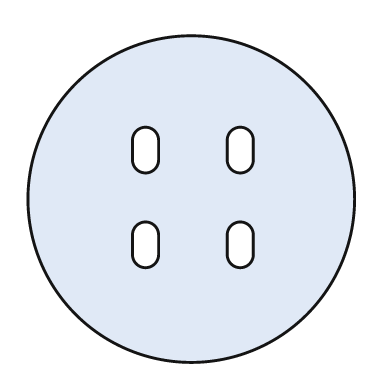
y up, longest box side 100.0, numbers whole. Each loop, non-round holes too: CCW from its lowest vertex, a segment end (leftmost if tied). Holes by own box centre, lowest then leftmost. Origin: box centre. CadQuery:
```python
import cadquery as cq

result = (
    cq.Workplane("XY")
    .moveTo(0.0, 0.0)
    .circle(50.0)
    .moveTo(-18.0, -17.0)
    .threePointArc((-14.0, -21.0), (-10.0, -17.0))
    .lineTo(-10.0, -11.0)
    .threePointArc((-14.0, -7.0), (-18.0, -11.0))
    .close()
    .moveTo(11.0, -17.0)
    .threePointArc((15.0, -21.0), (19.0, -17.0))
    .lineTo(19.0, -11.0)
    .threePointArc((15.0, -7.0), (11.0, -11.0))
    .close()
    .moveTo(-18.0, 12.0)
    .threePointArc((-14.0, 8.0), (-10.0, 12.0))
    .lineTo(-10.0, 18.0)
    .threePointArc((-14.0, 22.0), (-18.0, 18.0))
    .close()
    .moveTo(11.0, 12.0)
    .threePointArc((15.0, 8.0), (19.0, 12.0))
    .lineTo(19.0, 18.0)
    .threePointArc((15.0, 22.0), (11.0, 18.0))
    .close()
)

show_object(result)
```